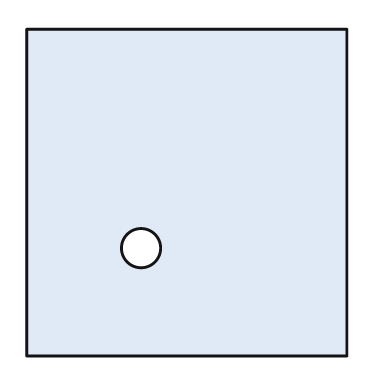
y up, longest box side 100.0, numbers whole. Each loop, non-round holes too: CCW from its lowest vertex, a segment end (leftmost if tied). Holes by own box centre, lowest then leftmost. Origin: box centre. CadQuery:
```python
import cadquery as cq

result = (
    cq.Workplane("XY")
    .moveTo(-49.0, -50.0)
    .lineTo(49.0, -50.0)
    .lineTo(49.0, 50.0)
    .lineTo(-49.0, 50.0)
    .close()
    .moveTo(-14.0, -17.0)
    .circle(6.0)
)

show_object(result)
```